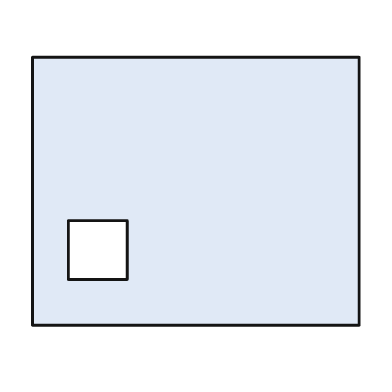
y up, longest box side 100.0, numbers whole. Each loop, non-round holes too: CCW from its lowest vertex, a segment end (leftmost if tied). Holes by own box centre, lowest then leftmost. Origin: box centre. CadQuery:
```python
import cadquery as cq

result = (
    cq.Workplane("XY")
    .moveTo(-50.0, -41.0)
    .lineTo(50.0, -41.0)
    .lineTo(50.0, 41.0)
    .lineTo(-50.0, 41.0)
    .close()
    .moveTo(-39.0, -27.0)
    .lineTo(-21.0, -27.0)
    .lineTo(-21.0, -9.0)
    .lineTo(-39.0, -9.0)
    .close()
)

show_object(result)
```